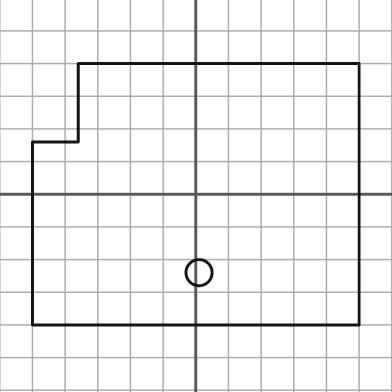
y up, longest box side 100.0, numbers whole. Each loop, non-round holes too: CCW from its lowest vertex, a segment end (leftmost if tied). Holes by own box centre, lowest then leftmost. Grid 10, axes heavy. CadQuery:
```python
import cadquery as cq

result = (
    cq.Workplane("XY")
    .moveTo(-50.0, -40.0)
    .lineTo(50.0, -40.0)
    .lineTo(50.0, 40.0)
    .lineTo(-36.0, 40.0)
    .lineTo(-36.0, 16.0)
    .lineTo(-50.0, 16.0)
    .close()
    .moveTo(1.0, -24.0)
    .circle(4.0)
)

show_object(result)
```